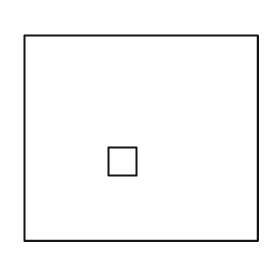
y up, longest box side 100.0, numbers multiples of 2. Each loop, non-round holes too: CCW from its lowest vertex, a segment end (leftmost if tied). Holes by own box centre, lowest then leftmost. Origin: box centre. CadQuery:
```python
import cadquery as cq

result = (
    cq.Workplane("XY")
    .moveTo(-50.0, -44.0)
    .lineTo(50.0, -44.0)
    .lineTo(50.0, 44.0)
    .lineTo(-50.0, 44.0)
    .close()
    .moveTo(-14.0, -16.0)
    .lineTo(-2.0, -16.0)
    .lineTo(-2.0, -4.0)
    .lineTo(-14.0, -4.0)
    .close()
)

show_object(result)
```